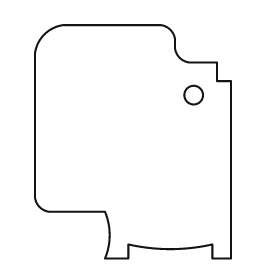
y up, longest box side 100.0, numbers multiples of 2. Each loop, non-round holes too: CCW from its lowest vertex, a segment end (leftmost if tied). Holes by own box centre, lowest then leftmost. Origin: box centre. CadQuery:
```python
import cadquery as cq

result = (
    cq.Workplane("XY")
    .moveTo(-12.0, -50.0)
    .lineTo(-2.0, -50.0)
    .lineTo(-2.0, -44.0)
    .threePointArc((16.0, -46.0), (34.0, -44.0))
    .lineTo(34.0, -50.0)
    .lineTo(42.0, -50.0)
    .lineTo(42.0, 26.0)
    .lineTo(36.0, 26.0)
    .lineTo(36.0, 34.0)
    .lineTo(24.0, 34.0)
    .threePointArc((20.0, 36.0), (18.0, 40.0))
    .lineTo(18.0, 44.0)
    .threePointArc((16.0, 48.0), (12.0, 50.0))
    .lineTo(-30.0, 50.0)
    .threePointArc((-38.0, 46.0), (-42.0, 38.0))
    .lineTo(-42.0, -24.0)
    .threePointArc((-40.0, -28.0), (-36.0, -30.0))
    .lineTo(-12.0, -30.0)
    .threePointArc((-10.0, -40.0), (-12.0, -50.0))
    .close()
    .moveTo(26.0, 20.0)
    .circle(4.0)
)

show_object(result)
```